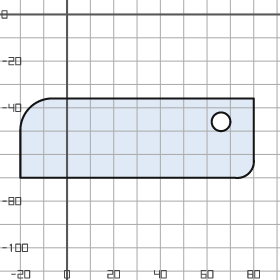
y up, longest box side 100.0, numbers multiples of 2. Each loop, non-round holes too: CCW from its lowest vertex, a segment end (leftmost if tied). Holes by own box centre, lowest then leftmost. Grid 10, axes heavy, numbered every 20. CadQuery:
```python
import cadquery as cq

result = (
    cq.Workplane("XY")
    .moveTo(-20.0, -70.0)
    .lineTo(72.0, -70.0)
    .threePointArc((78.0, -68.0), (80.0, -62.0))
    .lineTo(80.0, -36.0)
    .lineTo(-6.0, -36.0)
    .threePointArc((-16.0, -40.0), (-20.0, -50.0))
    .close()
    .moveTo(66.0, -46.0)
    .circle(4.0)
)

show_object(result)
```